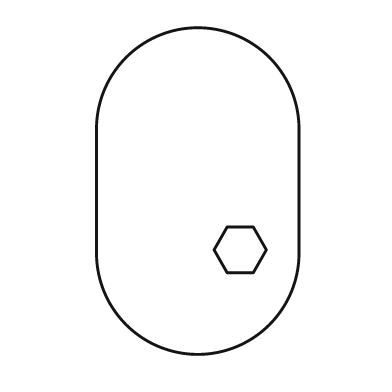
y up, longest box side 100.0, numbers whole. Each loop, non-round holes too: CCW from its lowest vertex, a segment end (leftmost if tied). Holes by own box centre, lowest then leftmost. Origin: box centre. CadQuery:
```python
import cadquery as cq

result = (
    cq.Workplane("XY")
    .moveTo(-31.0, -19.0)
    .threePointArc((0.0, -50.0), (31.0, -19.0))
    .lineTo(31.0, 19.0)
    .threePointArc((0.0, 50.0), (-31.0, 19.0))
    .close()
    .moveTo(9.0, -25.0)
    .lineTo(17.0, -25.0)
    .lineTo(21.0, -18.0)
    .lineTo(17.0, -11.0)
    .lineTo(9.0, -11.0)
    .lineTo(5.0, -18.0)
    .close()
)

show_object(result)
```